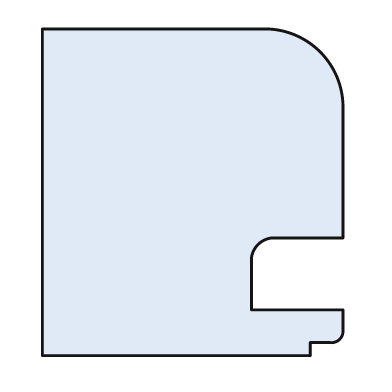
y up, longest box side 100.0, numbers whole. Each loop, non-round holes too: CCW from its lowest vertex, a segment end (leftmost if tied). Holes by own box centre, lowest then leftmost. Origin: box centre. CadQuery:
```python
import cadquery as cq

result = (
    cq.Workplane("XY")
    .moveTo(-46.0, -50.0)
    .lineTo(36.0, -50.0)
    .lineTo(36.0, -46.0)
    .lineTo(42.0, -46.0)
    .threePointArc((45.0, -45.0), (46.0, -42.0))
    .lineTo(46.0, -36.0)
    .lineTo(18.0, -36.0)
    .lineTo(18.0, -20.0)
    .threePointArc((20.0, -16.0), (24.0, -14.0))
    .lineTo(46.0, -14.0)
    .lineTo(46.0, 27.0)
    .threePointArc((39.0, 43.0), (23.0, 50.0))
    .lineTo(-46.0, 50.0)
    .close()
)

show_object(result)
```